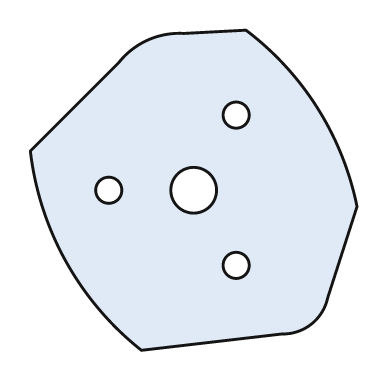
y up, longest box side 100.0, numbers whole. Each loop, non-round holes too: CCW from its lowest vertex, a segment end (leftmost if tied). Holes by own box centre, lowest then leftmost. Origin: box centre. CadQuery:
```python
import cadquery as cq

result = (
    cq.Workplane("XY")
    .moveTo(-16.0, -49.0)
    .lineTo(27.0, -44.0)
    .threePointArc((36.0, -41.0), (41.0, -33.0))
    .lineTo(50.0, -5.0)
    .threePointArc((38.0, 25.0), (16.0, 49.0))
    .lineTo(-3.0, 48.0)
    .threePointArc((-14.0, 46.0), (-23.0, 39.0))
    .lineTo(-50.0, 12.0)
    .threePointArc((-39.0, -22.0), (-16.0, -49.0))
    .close()
    .moveTo(13.0, -23.0)
    .circle(4.0)
    .moveTo(-26.0, 0.0)
    .circle(4.0)
    .moveTo(0.0, 0.0)
    .circle(7.0)
    .moveTo(13.0, 23.0)
    .circle(4.0)
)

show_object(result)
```